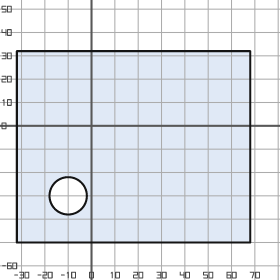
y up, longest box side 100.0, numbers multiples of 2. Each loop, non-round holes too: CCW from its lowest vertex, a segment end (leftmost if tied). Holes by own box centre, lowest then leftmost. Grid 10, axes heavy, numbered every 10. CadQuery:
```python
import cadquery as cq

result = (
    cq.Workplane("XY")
    .moveTo(-32.0, -50.0)
    .lineTo(68.0, -50.0)
    .lineTo(68.0, 32.0)
    .lineTo(-32.0, 32.0)
    .close()
    .moveTo(-10.0, -30.0)
    .circle(8.0)
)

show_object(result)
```